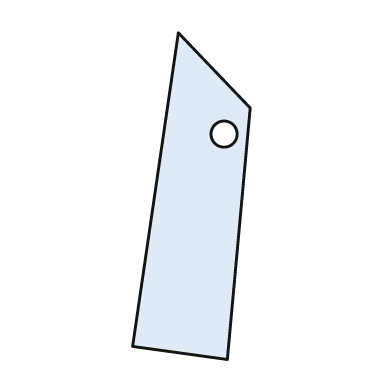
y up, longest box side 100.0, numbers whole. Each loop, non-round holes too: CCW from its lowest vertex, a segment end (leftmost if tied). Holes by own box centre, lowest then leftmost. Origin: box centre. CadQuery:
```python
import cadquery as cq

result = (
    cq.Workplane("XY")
    .moveTo(11.0, -50.0)
    .lineTo(18.0, 27.0)
    .lineTo(-4.0, 50.0)
    .lineTo(-18.0, -46.0)
    .close()
    .moveTo(10.0, 19.0)
    .circle(4.0)
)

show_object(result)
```